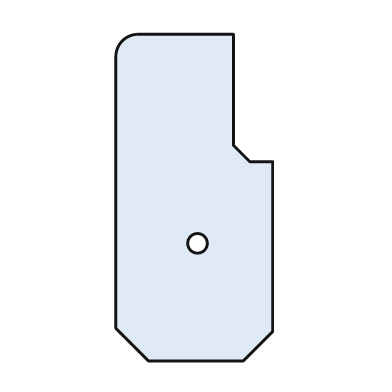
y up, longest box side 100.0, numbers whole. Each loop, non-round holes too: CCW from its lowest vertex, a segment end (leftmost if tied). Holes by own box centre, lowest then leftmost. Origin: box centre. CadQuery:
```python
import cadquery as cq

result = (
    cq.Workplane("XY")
    .moveTo(-14.0, -50.0)
    .lineTo(15.0, -50.0)
    .lineTo(24.0, -41.0)
    .lineTo(24.0, 11.0)
    .lineTo(17.0, 11.0)
    .lineTo(12.0, 16.0)
    .lineTo(12.0, 50.0)
    .lineTo(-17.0, 50.0)
    .threePointArc((-22.0, 48.0), (-24.0, 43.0))
    .lineTo(-24.0, -40.0)
    .close()
    .moveTo(1.0, -14.0)
    .circle(3.0)
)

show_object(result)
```